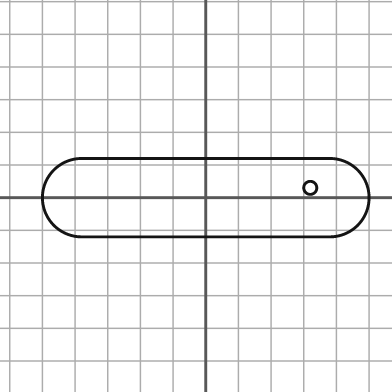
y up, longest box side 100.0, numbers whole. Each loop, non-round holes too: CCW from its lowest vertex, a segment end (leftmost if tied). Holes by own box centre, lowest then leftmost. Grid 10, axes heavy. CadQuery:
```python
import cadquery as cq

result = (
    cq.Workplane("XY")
    .moveTo(-38.0, -12.0)
    .lineTo(38.0, -12.0)
    .threePointArc((50.0, 0.0), (38.0, 12.0))
    .lineTo(-38.0, 12.0)
    .threePointArc((-50.0, 0.0), (-38.0, -12.0))
    .close()
    .moveTo(32.0, 3.0)
    .circle(2.0)
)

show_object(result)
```